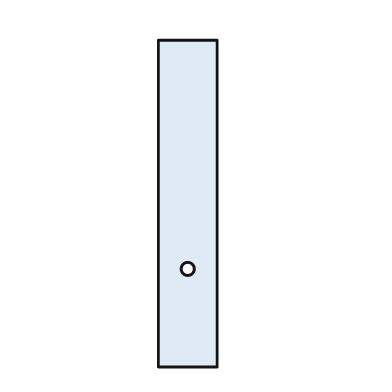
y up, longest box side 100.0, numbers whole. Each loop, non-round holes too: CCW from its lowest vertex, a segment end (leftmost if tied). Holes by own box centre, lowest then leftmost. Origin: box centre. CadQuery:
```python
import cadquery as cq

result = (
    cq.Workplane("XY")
    .moveTo(-9.0, -50.0)
    .lineTo(9.0, -50.0)
    .lineTo(9.0, 50.0)
    .lineTo(-9.0, 50.0)
    .close()
    .moveTo(0.0, -20.0)
    .circle(2.0)
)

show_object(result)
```